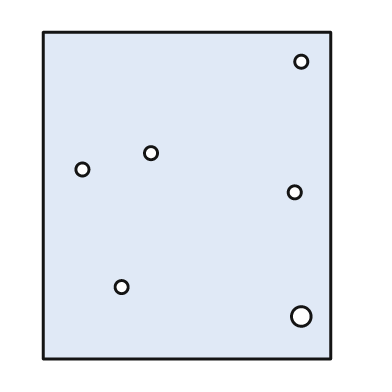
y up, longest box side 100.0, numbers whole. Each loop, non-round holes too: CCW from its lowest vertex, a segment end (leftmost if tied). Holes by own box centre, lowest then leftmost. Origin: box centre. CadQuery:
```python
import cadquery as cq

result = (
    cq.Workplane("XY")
    .moveTo(-44.0, -50.0)
    .lineTo(44.0, -50.0)
    .lineTo(44.0, 50.0)
    .lineTo(-44.0, 50.0)
    .close()
    .moveTo(35.0, -37.0)
    .circle(3.0)
    .moveTo(-20.0, -28.0)
    .circle(2.0)
    .moveTo(33.0, 1.0)
    .circle(2.0)
    .moveTo(-32.0, 8.0)
    .circle(2.0)
    .moveTo(-11.0, 13.0)
    .circle(2.0)
    .moveTo(35.0, 41.0)
    .circle(2.0)
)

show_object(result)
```